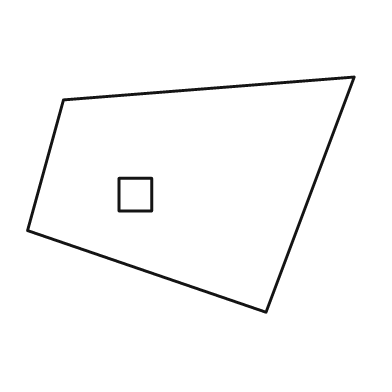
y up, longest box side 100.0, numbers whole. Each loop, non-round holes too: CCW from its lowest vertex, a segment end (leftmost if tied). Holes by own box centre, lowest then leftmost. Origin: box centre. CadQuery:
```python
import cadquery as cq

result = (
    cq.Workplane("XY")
    .moveTo(23.0, -36.0)
    .lineTo(50.0, 36.0)
    .lineTo(-39.0, 29.0)
    .lineTo(-50.0, -11.0)
    .close()
    .moveTo(-22.0, -5.0)
    .lineTo(-12.0, -5.0)
    .lineTo(-12.0, 5.0)
    .lineTo(-22.0, 5.0)
    .close()
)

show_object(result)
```